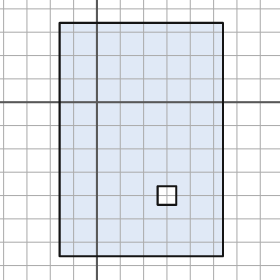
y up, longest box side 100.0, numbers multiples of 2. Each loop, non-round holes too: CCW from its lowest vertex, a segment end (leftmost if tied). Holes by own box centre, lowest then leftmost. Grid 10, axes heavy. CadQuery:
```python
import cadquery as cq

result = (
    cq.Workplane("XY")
    .moveTo(-16.0, -66.0)
    .lineTo(54.0, -66.0)
    .lineTo(54.0, 34.0)
    .lineTo(-16.0, 34.0)
    .close()
    .moveTo(26.0, -44.0)
    .lineTo(34.0, -44.0)
    .lineTo(34.0, -36.0)
    .lineTo(26.0, -36.0)
    .close()
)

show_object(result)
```